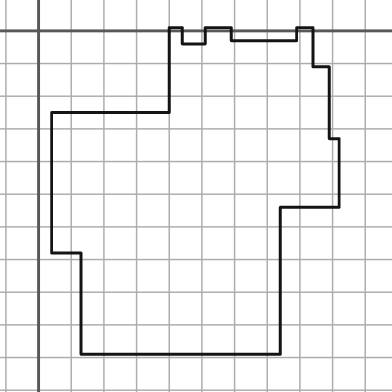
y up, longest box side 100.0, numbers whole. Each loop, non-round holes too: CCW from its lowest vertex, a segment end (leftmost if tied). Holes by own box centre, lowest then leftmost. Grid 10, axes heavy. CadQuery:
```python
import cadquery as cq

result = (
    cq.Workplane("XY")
    .moveTo(13.0, -99.0)
    .lineTo(74.0, -99.0)
    .lineTo(74.0, -54.0)
    .lineTo(92.0, -54.0)
    .lineTo(92.0, -33.0)
    .lineTo(89.0, -33.0)
    .lineTo(89.0, -11.0)
    .lineTo(84.0, -11.0)
    .lineTo(84.0, 1.0)
    .lineTo(79.0, 1.0)
    .lineTo(79.0, -3.0)
    .lineTo(59.0, -3.0)
    .lineTo(59.0, 1.0)
    .lineTo(51.0, 1.0)
    .lineTo(51.0, -4.0)
    .lineTo(44.0, -4.0)
    .lineTo(44.0, 1.0)
    .lineTo(40.0, 1.0)
    .lineTo(40.0, -25.0)
    .lineTo(4.0, -25.0)
    .lineTo(4.0, -68.0)
    .lineTo(13.0, -68.0)
    .close()
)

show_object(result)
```